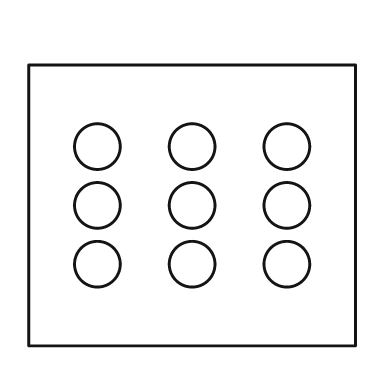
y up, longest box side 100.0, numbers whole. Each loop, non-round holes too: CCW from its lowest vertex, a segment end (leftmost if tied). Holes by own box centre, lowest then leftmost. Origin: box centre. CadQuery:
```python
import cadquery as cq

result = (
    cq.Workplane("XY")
    .moveTo(-50.0, -43.0)
    .lineTo(50.0, -43.0)
    .lineTo(50.0, 43.0)
    .lineTo(-50.0, 43.0)
    .close()
    .moveTo(-29.0, -18.0)
    .circle(7.0)
    .moveTo(0.0, -18.0)
    .circle(7.0)
    .moveTo(29.0, -18.0)
    .circle(7.0)
    .moveTo(-29.0, 0.0)
    .circle(7.0)
    .moveTo(0.0, 0.0)
    .circle(7.0)
    .moveTo(29.0, 0.0)
    .circle(7.0)
    .moveTo(-29.0, 18.0)
    .circle(7.0)
    .moveTo(0.0, 18.0)
    .circle(7.0)
    .moveTo(29.0, 18.0)
    .circle(7.0)
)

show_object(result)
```